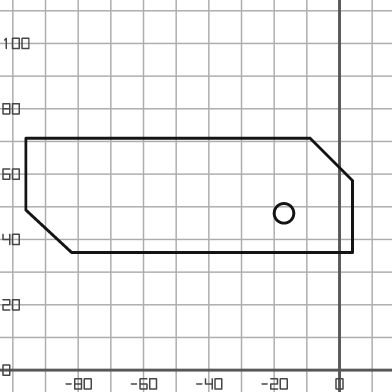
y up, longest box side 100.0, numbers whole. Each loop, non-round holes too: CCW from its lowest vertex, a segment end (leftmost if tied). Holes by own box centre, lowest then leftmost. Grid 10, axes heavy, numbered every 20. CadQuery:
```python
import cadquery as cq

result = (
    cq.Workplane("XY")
    .moveTo(-82.0, 36.0)
    .lineTo(4.0, 36.0)
    .lineTo(4.0, 58.0)
    .lineTo(-9.0, 71.0)
    .lineTo(-96.0, 71.0)
    .lineTo(-96.0, 49.0)
    .close()
    .moveTo(-17.0, 48.0)
    .circle(3.0)
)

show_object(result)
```